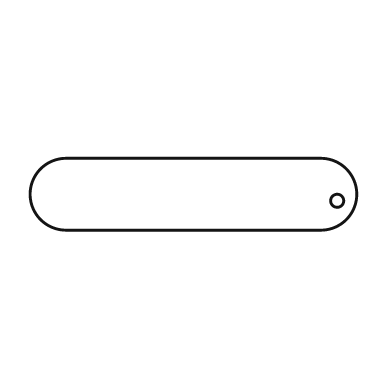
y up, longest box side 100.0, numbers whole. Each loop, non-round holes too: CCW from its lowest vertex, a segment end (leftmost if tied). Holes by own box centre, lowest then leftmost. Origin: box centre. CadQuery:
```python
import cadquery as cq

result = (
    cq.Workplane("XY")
    .moveTo(-39.0, -11.0)
    .lineTo(39.0, -11.0)
    .threePointArc((50.0, 0.0), (39.0, 11.0))
    .lineTo(-39.0, 11.0)
    .threePointArc((-50.0, 0.0), (-39.0, -11.0))
    .close()
    .moveTo(44.0, -2.0)
    .circle(2.0)
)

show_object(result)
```